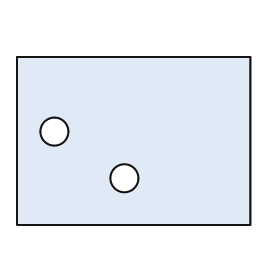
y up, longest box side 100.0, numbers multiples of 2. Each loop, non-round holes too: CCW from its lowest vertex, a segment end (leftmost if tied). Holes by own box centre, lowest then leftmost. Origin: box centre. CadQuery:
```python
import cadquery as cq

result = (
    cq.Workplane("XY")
    .moveTo(-50.0, -36.0)
    .lineTo(50.0, -36.0)
    .lineTo(50.0, 36.0)
    .lineTo(-50.0, 36.0)
    .close()
    .moveTo(-4.0, -16.0)
    .circle(6.0)
    .moveTo(-34.0, 4.0)
    .circle(6.0)
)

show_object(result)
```